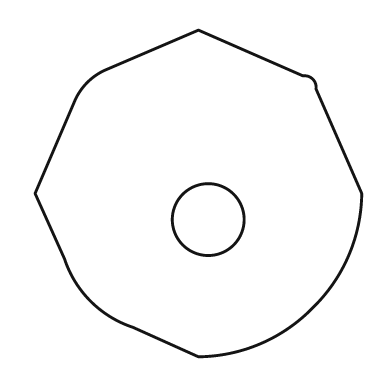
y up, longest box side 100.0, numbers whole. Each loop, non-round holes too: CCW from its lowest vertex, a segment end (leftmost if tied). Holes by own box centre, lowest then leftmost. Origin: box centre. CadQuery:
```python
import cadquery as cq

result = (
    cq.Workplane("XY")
    .moveTo(0.0, -50.0)
    .threePointArc((19.0, -46.0), (35.0, -35.0))
    .threePointArc((46.0, -19.0), (50.0, 0.0))
    .lineTo(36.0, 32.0)
    .threePointArc((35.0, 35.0), (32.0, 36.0))
    .lineTo(0.0, 50.0)
    .lineTo(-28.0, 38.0)
    .threePointArc((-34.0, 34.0), (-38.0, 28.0))
    .lineTo(-50.0, 0.0)
    .lineTo(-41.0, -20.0)
    .threePointArc((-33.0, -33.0), (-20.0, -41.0))
    .close()
    .moveTo(3.0, -8.0)
    .circle(11.0)
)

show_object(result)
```